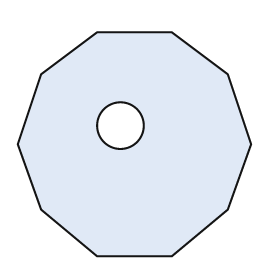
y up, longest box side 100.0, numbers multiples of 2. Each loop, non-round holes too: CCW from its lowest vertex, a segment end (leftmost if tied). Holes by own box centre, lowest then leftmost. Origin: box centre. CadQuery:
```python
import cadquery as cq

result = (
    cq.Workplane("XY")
    .moveTo(-16.0, -48.0)
    .lineTo(16.0, -48.0)
    .lineTo(40.0, -28.0)
    .lineTo(50.0, 0.0)
    .lineTo(40.0, 30.0)
    .lineTo(16.0, 48.0)
    .lineTo(-16.0, 48.0)
    .lineTo(-40.0, 30.0)
    .lineTo(-50.0, 0.0)
    .lineTo(-40.0, -28.0)
    .close()
    .moveTo(-6.0, 8.0)
    .circle(10.0)
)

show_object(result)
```